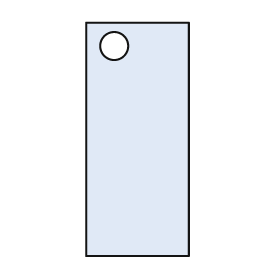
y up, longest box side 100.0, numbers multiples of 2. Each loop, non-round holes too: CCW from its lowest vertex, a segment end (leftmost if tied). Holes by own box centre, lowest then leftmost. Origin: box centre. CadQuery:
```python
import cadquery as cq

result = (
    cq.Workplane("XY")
    .moveTo(-22.0, -50.0)
    .lineTo(22.0, -50.0)
    .lineTo(22.0, 50.0)
    .lineTo(-22.0, 50.0)
    .close()
    .moveTo(-10.0, 40.0)
    .circle(6.0)
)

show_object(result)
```